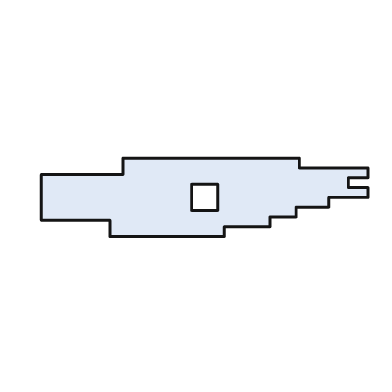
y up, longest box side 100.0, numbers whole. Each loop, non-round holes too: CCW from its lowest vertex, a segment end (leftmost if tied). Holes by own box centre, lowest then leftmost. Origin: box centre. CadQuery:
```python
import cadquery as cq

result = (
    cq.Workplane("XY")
    .moveTo(-29.0, -12.0)
    .lineTo(6.0, -12.0)
    .lineTo(6.0, -9.0)
    .lineTo(20.0, -9.0)
    .lineTo(20.0, -6.0)
    .lineTo(28.0, -6.0)
    .lineTo(28.0, -3.0)
    .lineTo(38.0, -3.0)
    .lineTo(38.0, 0.0)
    .lineTo(50.0, 0.0)
    .lineTo(50.0, 3.0)
    .lineTo(44.0, 3.0)
    .lineTo(44.0, 6.0)
    .lineTo(50.0, 6.0)
    .lineTo(50.0, 9.0)
    .lineTo(29.0, 9.0)
    .lineTo(29.0, 12.0)
    .lineTo(-25.0, 12.0)
    .lineTo(-25.0, 7.0)
    .lineTo(-50.0, 7.0)
    .lineTo(-50.0, -7.0)
    .lineTo(-29.0, -7.0)
    .close()
    .moveTo(-4.0, -4.0)
    .lineTo(4.0, -4.0)
    .lineTo(4.0, 4.0)
    .lineTo(-4.0, 4.0)
    .close()
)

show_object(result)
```